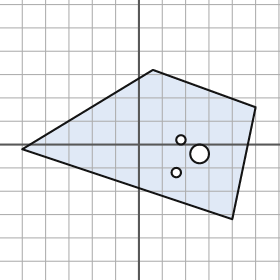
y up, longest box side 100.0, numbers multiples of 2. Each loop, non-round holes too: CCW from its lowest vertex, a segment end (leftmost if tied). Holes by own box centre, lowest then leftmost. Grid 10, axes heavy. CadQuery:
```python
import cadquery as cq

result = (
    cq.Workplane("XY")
    .moveTo(40.0, -32.0)
    .lineTo(50.0, 16.0)
    .lineTo(6.0, 32.0)
    .lineTo(-50.0, -2.0)
    .close()
    .moveTo(16.0, -12.0)
    .circle(2.0)
    .moveTo(26.0, -4.0)
    .circle(4.0)
    .moveTo(18.0, 2.0)
    .circle(2.0)
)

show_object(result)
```